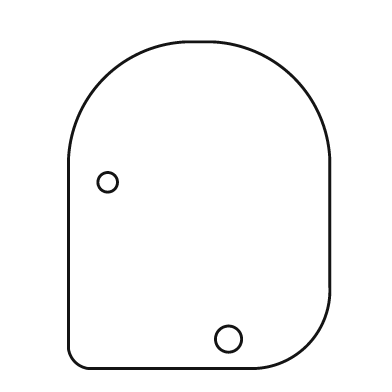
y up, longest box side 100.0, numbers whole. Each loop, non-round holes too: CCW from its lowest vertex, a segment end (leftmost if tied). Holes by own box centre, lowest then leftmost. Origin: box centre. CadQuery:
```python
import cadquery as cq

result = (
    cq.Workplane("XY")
    .moveTo(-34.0, -50.0)
    .lineTo(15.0, -50.0)
    .threePointArc((33.0, -43.0), (40.0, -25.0))
    .lineTo(40.0, 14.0)
    .threePointArc((29.0, 39.0), (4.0, 50.0))
    .lineTo(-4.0, 50.0)
    .threePointArc((-29.0, 39.0), (-40.0, 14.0))
    .lineTo(-40.0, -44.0)
    .threePointArc((-38.0, -48.0), (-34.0, -50.0))
    .close()
    .moveTo(9.0, -41.0)
    .circle(4.0)
    .moveTo(-28.0, 7.0)
    .circle(3.0)
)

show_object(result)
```